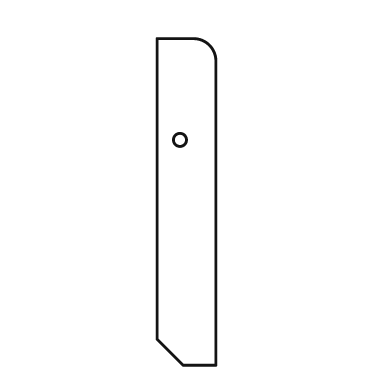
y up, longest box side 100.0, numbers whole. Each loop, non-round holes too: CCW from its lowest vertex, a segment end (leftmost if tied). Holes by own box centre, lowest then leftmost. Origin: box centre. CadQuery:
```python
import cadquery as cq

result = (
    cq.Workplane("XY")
    .moveTo(-1.0, -50.0)
    .lineTo(9.0, -50.0)
    .lineTo(9.0, 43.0)
    .threePointArc((7.0, 48.0), (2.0, 50.0))
    .lineTo(-9.0, 50.0)
    .lineTo(-9.0, -42.0)
    .close()
    .moveTo(-2.0, 19.0)
    .circle(2.0)
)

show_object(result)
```